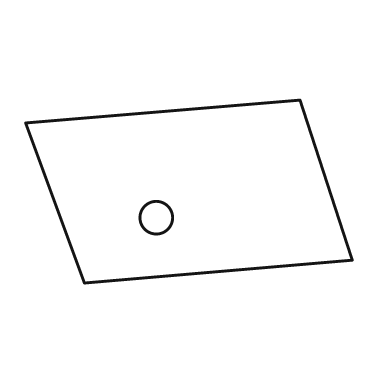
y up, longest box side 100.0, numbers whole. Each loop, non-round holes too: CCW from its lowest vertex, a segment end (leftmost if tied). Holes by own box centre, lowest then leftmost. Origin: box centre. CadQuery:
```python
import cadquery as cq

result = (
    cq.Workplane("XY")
    .moveTo(-32.0, -28.0)
    .lineTo(50.0, -21.0)
    .lineTo(34.0, 28.0)
    .lineTo(-50.0, 21.0)
    .close()
    .moveTo(-10.0, -8.0)
    .circle(5.0)
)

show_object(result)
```